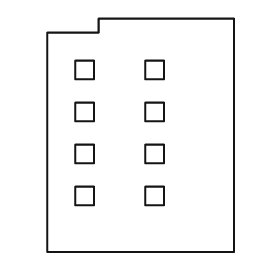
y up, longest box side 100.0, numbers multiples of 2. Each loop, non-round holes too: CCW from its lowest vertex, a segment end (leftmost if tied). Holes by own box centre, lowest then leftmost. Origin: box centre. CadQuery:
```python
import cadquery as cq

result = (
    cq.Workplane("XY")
    .moveTo(-40.0, -50.0)
    .lineTo(40.0, -50.0)
    .lineTo(40.0, 50.0)
    .lineTo(-18.0, 50.0)
    .lineTo(-18.0, 44.0)
    .lineTo(-40.0, 44.0)
    .close()
    .moveTo(-28.0, -30.0)
    .lineTo(-20.0, -30.0)
    .lineTo(-20.0, -22.0)
    .lineTo(-28.0, -22.0)
    .close()
    .moveTo(2.0, -30.0)
    .lineTo(10.0, -30.0)
    .lineTo(10.0, -22.0)
    .lineTo(2.0, -22.0)
    .close()
    .moveTo(-28.0, -12.0)
    .lineTo(-20.0, -12.0)
    .lineTo(-20.0, -4.0)
    .lineTo(-28.0, -4.0)
    .close()
    .moveTo(2.0, -12.0)
    .lineTo(10.0, -12.0)
    .lineTo(10.0, -4.0)
    .lineTo(2.0, -4.0)
    .close()
    .moveTo(-28.0, 6.0)
    .lineTo(-20.0, 6.0)
    .lineTo(-20.0, 14.0)
    .lineTo(-28.0, 14.0)
    .close()
    .moveTo(2.0, 6.0)
    .lineTo(10.0, 6.0)
    .lineTo(10.0, 14.0)
    .lineTo(2.0, 14.0)
    .close()
    .moveTo(-28.0, 24.0)
    .lineTo(-20.0, 24.0)
    .lineTo(-20.0, 32.0)
    .lineTo(-28.0, 32.0)
    .close()
    .moveTo(2.0, 24.0)
    .lineTo(10.0, 24.0)
    .lineTo(10.0, 32.0)
    .lineTo(2.0, 32.0)
    .close()
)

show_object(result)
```